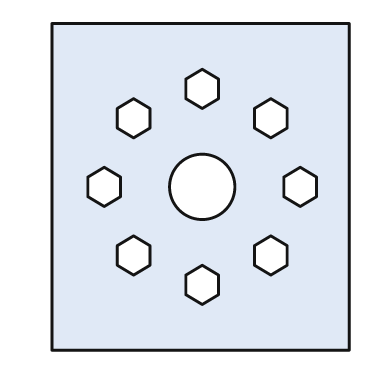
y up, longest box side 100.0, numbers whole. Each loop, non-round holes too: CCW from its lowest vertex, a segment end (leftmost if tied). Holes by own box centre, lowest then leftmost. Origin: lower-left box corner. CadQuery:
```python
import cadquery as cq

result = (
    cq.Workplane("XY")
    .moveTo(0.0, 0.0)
    .lineTo(91.0, 0.0)
    .lineTo(91.0, 100.0)
    .lineTo(0.0, 100.0)
    .close()
    .moveTo(46.0, 14.0)
    .lineTo(51.0, 17.0)
    .lineTo(51.0, 23.0)
    .lineTo(46.0, 26.0)
    .lineTo(41.0, 23.0)
    .lineTo(41.0, 17.0)
    .close()
    .moveTo(25.0, 23.0)
    .lineTo(30.0, 26.0)
    .lineTo(30.0, 32.0)
    .lineTo(25.0, 35.0)
    .lineTo(20.0, 32.0)
    .lineTo(20.0, 26.0)
    .close()
    .moveTo(67.0, 23.0)
    .lineTo(72.0, 26.0)
    .lineTo(72.0, 32.0)
    .lineTo(67.0, 35.0)
    .lineTo(62.0, 32.0)
    .lineTo(62.0, 26.0)
    .close()
    .moveTo(16.0, 44.0)
    .lineTo(21.0, 47.0)
    .lineTo(21.0, 53.0)
    .lineTo(16.0, 56.0)
    .lineTo(11.0, 53.0)
    .lineTo(11.0, 47.0)
    .close()
    .moveTo(46.0, 50.0)
    .circle(10.0)
    .moveTo(76.0, 44.0)
    .lineTo(81.0, 47.0)
    .lineTo(81.0, 53.0)
    .lineTo(76.0, 56.0)
    .lineTo(71.0, 53.0)
    .lineTo(71.0, 47.0)
    .close()
    .moveTo(25.0, 65.0)
    .lineTo(30.0, 68.0)
    .lineTo(30.0, 74.0)
    .lineTo(25.0, 77.0)
    .lineTo(20.0, 74.0)
    .lineTo(20.0, 68.0)
    .close()
    .moveTo(67.0, 65.0)
    .lineTo(72.0, 68.0)
    .lineTo(72.0, 74.0)
    .lineTo(67.0, 77.0)
    .lineTo(62.0, 74.0)
    .lineTo(62.0, 68.0)
    .close()
    .moveTo(46.0, 74.0)
    .lineTo(51.0, 77.0)
    .lineTo(51.0, 83.0)
    .lineTo(46.0, 86.0)
    .lineTo(41.0, 83.0)
    .lineTo(41.0, 77.0)
    .close()
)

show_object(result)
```